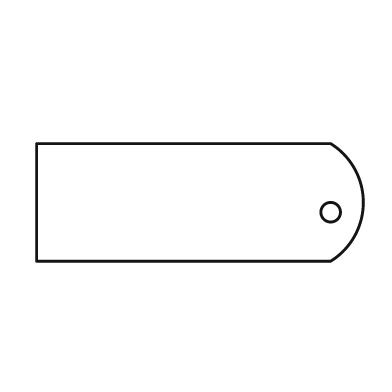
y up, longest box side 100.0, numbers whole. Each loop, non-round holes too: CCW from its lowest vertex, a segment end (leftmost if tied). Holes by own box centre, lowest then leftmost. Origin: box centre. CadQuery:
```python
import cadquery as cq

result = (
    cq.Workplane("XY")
    .moveTo(-50.0, -18.0)
    .lineTo(40.0, -18.0)
    .threePointArc((50.0, 0.0), (40.0, 18.0))
    .lineTo(-50.0, 18.0)
    .close()
    .moveTo(40.0, -3.0)
    .circle(3.0)
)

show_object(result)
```